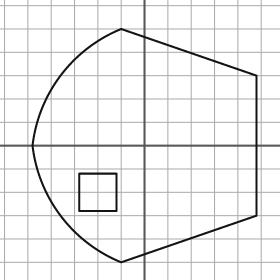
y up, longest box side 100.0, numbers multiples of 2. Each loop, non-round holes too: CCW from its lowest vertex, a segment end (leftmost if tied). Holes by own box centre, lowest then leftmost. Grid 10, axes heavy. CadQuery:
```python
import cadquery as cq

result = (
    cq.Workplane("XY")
    .moveTo(-10.0, -50.0)
    .lineTo(48.0, -30.0)
    .lineTo(48.0, 30.0)
    .lineTo(-10.0, 50.0)
    .threePointArc((-36.0, 30.0), (-48.0, 0.0))
    .threePointArc((-36.0, -30.0), (-10.0, -50.0))
    .close()
    .moveTo(-28.0, -28.0)
    .lineTo(-12.0, -28.0)
    .lineTo(-12.0, -12.0)
    .lineTo(-28.0, -12.0)
    .close()
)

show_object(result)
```